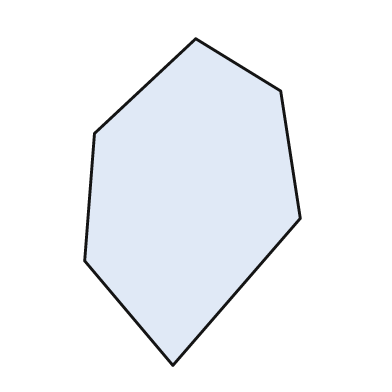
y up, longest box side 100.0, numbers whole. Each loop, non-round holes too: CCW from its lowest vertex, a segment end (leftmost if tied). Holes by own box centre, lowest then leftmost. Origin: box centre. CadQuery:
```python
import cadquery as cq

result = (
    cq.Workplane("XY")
    .moveTo(-6.0, -50.0)
    .lineTo(33.0, -5.0)
    .lineTo(27.0, 34.0)
    .lineTo(1.0, 50.0)
    .lineTo(-30.0, 21.0)
    .lineTo(-33.0, -18.0)
    .close()
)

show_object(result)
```